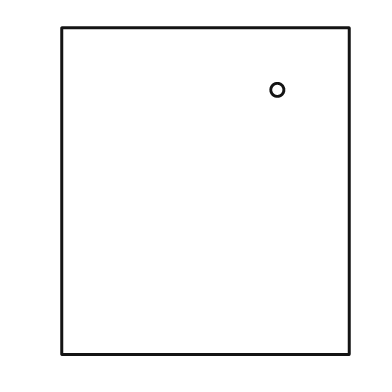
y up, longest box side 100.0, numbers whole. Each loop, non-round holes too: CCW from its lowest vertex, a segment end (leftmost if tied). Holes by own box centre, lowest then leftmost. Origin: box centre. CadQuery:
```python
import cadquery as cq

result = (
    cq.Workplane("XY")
    .moveTo(-44.0, -50.0)
    .lineTo(44.0, -50.0)
    .lineTo(44.0, 50.0)
    .lineTo(-44.0, 50.0)
    .close()
    .moveTo(22.0, 31.0)
    .circle(2.0)
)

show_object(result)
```